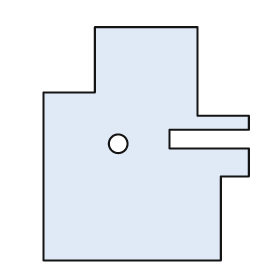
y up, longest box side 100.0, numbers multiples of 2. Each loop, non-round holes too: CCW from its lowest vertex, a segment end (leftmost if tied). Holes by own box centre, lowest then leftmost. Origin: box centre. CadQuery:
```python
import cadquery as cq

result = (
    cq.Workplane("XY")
    .moveTo(-44.0, -50.0)
    .lineTo(32.0, -50.0)
    .lineTo(32.0, -14.0)
    .lineTo(44.0, -14.0)
    .lineTo(44.0, -2.0)
    .lineTo(10.0, -2.0)
    .lineTo(10.0, 6.0)
    .lineTo(44.0, 6.0)
    .lineTo(44.0, 12.0)
    .lineTo(22.0, 12.0)
    .lineTo(22.0, 50.0)
    .lineTo(-22.0, 50.0)
    .lineTo(-22.0, 22.0)
    .lineTo(-44.0, 22.0)
    .close()
    .moveTo(-12.0, 0.0)
    .circle(4.0)
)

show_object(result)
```